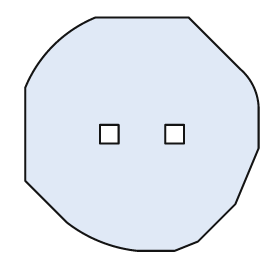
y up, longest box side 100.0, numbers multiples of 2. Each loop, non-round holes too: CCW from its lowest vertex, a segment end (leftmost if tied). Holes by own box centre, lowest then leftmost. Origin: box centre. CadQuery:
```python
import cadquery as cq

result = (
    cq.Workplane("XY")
    .moveTo(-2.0, -50.0)
    .lineTo(14.0, -50.0)
    .lineTo(24.0, -46.0)
    .lineTo(40.0, -30.0)
    .lineTo(50.0, -6.0)
    .lineTo(50.0, 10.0)
    .threePointArc((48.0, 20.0), (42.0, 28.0))
    .lineTo(20.0, 50.0)
    .lineTo(-20.0, 50.0)
    .threePointArc((-38.0, 38.0), (-50.0, 20.0))
    .lineTo(-50.0, -20.0)
    .lineTo(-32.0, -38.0)
    .threePointArc((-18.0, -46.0), (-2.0, -50.0))
    .close()
    .moveTo(-18.0, -4.0)
    .lineTo(-10.0, -4.0)
    .lineTo(-10.0, 4.0)
    .lineTo(-18.0, 4.0)
    .close()
    .moveTo(10.0, -4.0)
    .lineTo(18.0, -4.0)
    .lineTo(18.0, 4.0)
    .lineTo(10.0, 4.0)
    .close()
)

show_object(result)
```